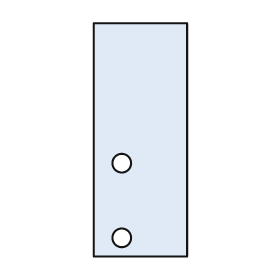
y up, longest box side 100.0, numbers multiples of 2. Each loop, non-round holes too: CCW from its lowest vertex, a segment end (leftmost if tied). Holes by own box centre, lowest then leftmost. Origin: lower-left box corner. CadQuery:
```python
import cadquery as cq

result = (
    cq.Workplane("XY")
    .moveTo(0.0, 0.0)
    .lineTo(40.0, 0.0)
    .lineTo(40.0, 100.0)
    .lineTo(0.0, 100.0)
    .close()
    .moveTo(12.0, 8.0)
    .circle(4.0)
    .moveTo(12.0, 40.0)
    .circle(4.0)
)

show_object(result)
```